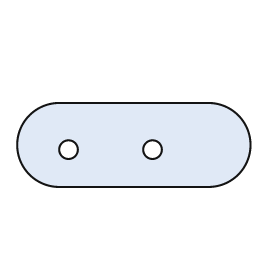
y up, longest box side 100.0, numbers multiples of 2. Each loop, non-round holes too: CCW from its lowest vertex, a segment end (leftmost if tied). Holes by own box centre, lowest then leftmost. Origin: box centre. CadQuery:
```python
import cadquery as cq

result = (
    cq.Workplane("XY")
    .moveTo(-32.0, -18.0)
    .lineTo(32.0, -18.0)
    .threePointArc((50.0, 0.0), (32.0, 18.0))
    .lineTo(-32.0, 18.0)
    .threePointArc((-50.0, 0.0), (-32.0, -18.0))
    .close()
    .moveTo(-28.0, -2.0)
    .circle(4.0)
    .moveTo(8.0, -2.0)
    .circle(4.0)
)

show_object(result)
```